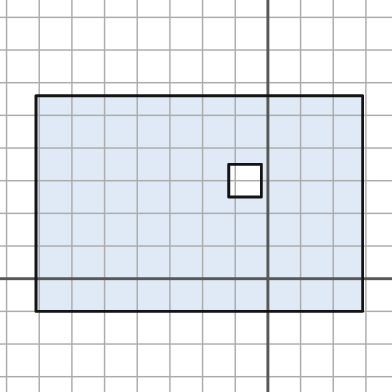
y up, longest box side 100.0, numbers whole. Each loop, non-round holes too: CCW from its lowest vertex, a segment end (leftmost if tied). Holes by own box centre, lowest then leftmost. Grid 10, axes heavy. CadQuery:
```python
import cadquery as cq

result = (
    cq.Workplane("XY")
    .moveTo(-71.0, -10.0)
    .lineTo(29.0, -10.0)
    .lineTo(29.0, 56.0)
    .lineTo(-71.0, 56.0)
    .close()
    .moveTo(-12.0, 25.0)
    .lineTo(-2.0, 25.0)
    .lineTo(-2.0, 35.0)
    .lineTo(-12.0, 35.0)
    .close()
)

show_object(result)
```